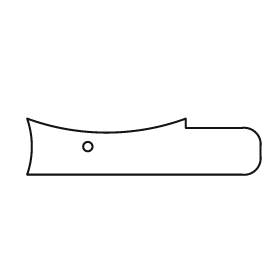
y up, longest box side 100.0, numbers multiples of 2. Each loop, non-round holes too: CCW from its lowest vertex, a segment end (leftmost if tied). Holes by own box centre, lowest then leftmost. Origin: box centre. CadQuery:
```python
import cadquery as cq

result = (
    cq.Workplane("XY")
    .moveTo(-50.0, -12.0)
    .lineTo(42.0, -12.0)
    .threePointArc((48.0, -10.0), (50.0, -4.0))
    .lineTo(50.0, 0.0)
    .threePointArc((48.0, 6.0), (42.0, 8.0))
    .lineTo(18.0, 8.0)
    .lineTo(18.0, 12.0)
    .threePointArc((-16.0, 6.0), (-50.0, 12.0))
    .threePointArc((-48.0, 0.0), (-50.0, -12.0))
    .close()
    .moveTo(-24.0, 0.0)
    .circle(2.0)
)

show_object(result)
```